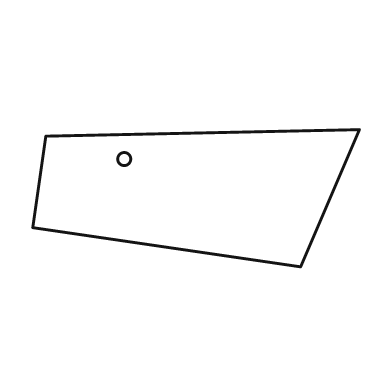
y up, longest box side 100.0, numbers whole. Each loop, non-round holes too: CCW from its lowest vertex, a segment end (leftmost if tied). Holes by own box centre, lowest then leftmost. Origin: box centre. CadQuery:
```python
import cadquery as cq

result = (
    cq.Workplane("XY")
    .moveTo(32.0, -21.0)
    .lineTo(50.0, 21.0)
    .lineTo(-46.0, 19.0)
    .lineTo(-50.0, -9.0)
    .close()
    .moveTo(-22.0, 12.0)
    .circle(2.0)
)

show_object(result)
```